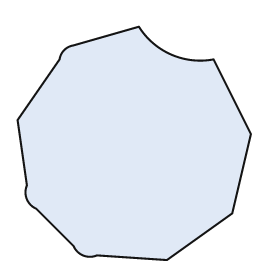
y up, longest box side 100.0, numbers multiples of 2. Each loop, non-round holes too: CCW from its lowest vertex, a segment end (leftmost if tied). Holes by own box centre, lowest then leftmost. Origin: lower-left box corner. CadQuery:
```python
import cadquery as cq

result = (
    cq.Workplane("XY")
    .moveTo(64.0, 0.0)
    .lineTo(92.0, 20.0)
    .lineTo(100.0, 54.0)
    .lineTo(84.0, 86.0)
    .threePointArc((66.0, 88.0), (52.0, 100.0))
    .lineTo(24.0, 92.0)
    .threePointArc((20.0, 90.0), (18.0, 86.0))
    .lineTo(0.0, 60.0)
    .lineTo(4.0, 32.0)
    .threePointArc((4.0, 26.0), (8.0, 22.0))
    .lineTo(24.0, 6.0)
    .threePointArc((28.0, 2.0), (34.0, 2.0))
    .close()
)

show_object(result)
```